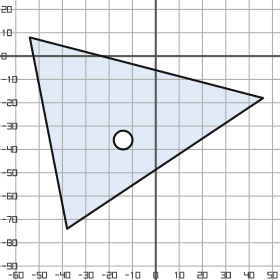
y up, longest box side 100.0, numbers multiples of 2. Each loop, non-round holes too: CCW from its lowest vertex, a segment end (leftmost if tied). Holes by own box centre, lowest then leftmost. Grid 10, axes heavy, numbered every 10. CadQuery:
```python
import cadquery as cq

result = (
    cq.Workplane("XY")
    .moveTo(-38.0, -74.0)
    .lineTo(46.0, -18.0)
    .lineTo(-54.0, 8.0)
    .close()
    .moveTo(-14.0, -36.0)
    .circle(4.0)
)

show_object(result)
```